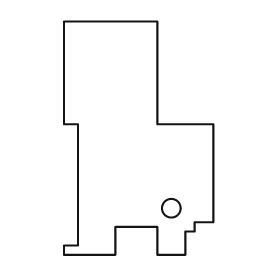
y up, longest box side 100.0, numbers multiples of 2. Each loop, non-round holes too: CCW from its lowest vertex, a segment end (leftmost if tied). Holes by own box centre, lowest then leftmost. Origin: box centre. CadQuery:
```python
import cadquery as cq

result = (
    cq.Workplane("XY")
    .moveTo(-32.0, -50.0)
    .lineTo(-10.0, -50.0)
    .lineTo(-10.0, -38.0)
    .lineTo(8.0, -38.0)
    .lineTo(8.0, -50.0)
    .lineTo(20.0, -50.0)
    .lineTo(20.0, -40.0)
    .lineTo(24.0, -40.0)
    .lineTo(24.0, -36.0)
    .lineTo(32.0, -36.0)
    .lineTo(32.0, 6.0)
    .lineTo(8.0, 6.0)
    .lineTo(8.0, 50.0)
    .lineTo(-32.0, 50.0)
    .lineTo(-32.0, 6.0)
    .lineTo(-26.0, 6.0)
    .lineTo(-26.0, -46.0)
    .lineTo(-32.0, -46.0)
    .close()
    .moveTo(14.0, -30.0)
    .circle(4.0)
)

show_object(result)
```